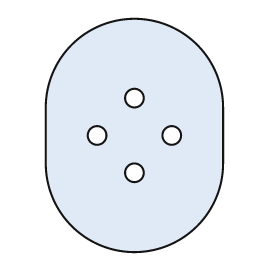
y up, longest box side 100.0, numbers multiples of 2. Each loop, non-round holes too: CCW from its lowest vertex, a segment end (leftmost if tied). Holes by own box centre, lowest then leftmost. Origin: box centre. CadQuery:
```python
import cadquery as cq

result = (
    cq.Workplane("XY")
    .moveTo(-38.0, -12.0)
    .threePointArc((0.0, -50.0), (38.0, -12.0))
    .lineTo(38.0, 12.0)
    .threePointArc((0.0, 50.0), (-38.0, 12.0))
    .close()
    .moveTo(0.0, -16.0)
    .circle(4.0)
    .moveTo(-16.0, 0.0)
    .circle(4.0)
    .moveTo(16.0, 0.0)
    .circle(4.0)
    .moveTo(0.0, 16.0)
    .circle(4.0)
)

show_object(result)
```